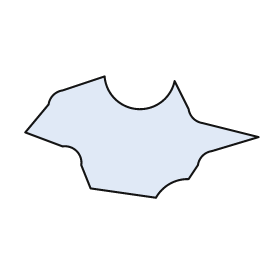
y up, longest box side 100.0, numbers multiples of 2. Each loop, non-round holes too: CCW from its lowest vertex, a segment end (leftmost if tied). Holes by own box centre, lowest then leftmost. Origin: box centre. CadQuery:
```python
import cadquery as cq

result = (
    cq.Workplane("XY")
    .moveTo(6.0, -26.0)
    .threePointArc((12.0, -20.0), (20.0, -18.0))
    .lineTo(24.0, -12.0)
    .threePointArc((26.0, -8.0), (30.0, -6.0))
    .lineTo(50.0, 0.0)
    .lineTo(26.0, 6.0)
    .threePointArc((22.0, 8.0), (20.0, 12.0))
    .lineTo(14.0, 24.0)
    .threePointArc((-2.0, 12.0), (-16.0, 26.0))
    .lineTo(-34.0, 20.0)
    .threePointArc((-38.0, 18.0), (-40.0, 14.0))
    .lineTo(-50.0, 2.0)
    .lineTo(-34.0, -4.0)
    .threePointArc((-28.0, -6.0), (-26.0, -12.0))
    .lineTo(-22.0, -22.0)
    .close()
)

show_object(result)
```